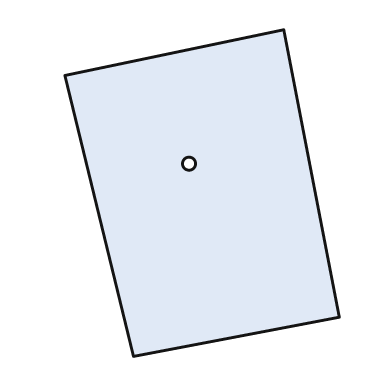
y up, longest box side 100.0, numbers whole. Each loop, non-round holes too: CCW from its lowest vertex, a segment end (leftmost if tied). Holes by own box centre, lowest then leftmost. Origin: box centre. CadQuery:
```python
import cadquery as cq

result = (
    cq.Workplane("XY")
    .moveTo(-21.0, -50.0)
    .lineTo(42.0, -38.0)
    .lineTo(25.0, 50.0)
    .lineTo(-42.0, 36.0)
    .close()
    .moveTo(-4.0, 9.0)
    .circle(2.0)
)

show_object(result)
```